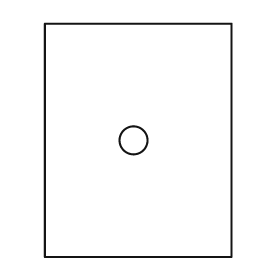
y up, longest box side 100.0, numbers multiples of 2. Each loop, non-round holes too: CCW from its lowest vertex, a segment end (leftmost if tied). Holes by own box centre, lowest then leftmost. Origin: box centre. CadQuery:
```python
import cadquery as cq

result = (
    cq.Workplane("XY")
    .moveTo(-40.0, -50.0)
    .lineTo(40.0, -50.0)
    .lineTo(40.0, 50.0)
    .lineTo(-40.0, 50.0)
    .close()
    .moveTo(-2.0, 0.0)
    .circle(6.0)
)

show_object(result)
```